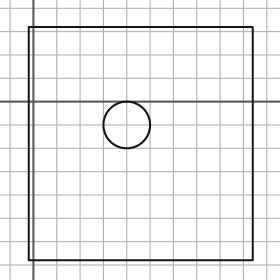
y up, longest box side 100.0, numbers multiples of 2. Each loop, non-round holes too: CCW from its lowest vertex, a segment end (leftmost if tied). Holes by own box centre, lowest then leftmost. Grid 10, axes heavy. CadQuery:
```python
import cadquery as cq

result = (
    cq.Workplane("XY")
    .moveTo(-2.0, -68.0)
    .lineTo(94.0, -68.0)
    .lineTo(94.0, 32.0)
    .lineTo(-2.0, 32.0)
    .close()
    .moveTo(40.0, -10.0)
    .circle(10.0)
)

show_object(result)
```